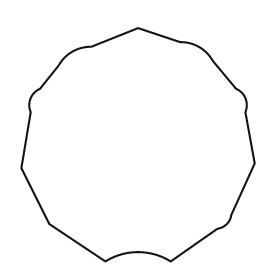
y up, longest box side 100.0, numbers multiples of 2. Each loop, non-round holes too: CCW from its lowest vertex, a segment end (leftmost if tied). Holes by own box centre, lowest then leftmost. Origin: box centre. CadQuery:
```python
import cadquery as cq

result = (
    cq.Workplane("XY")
    .moveTo(-14.0, -50.0)
    .threePointArc((0.0, -46.0), (14.0, -50.0))
    .lineTo(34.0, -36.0)
    .threePointArc((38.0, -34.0), (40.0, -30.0))
    .lineTo(50.0, -8.0)
    .lineTo(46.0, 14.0)
    .threePointArc((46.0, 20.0), (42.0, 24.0))
    .lineTo(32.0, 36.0)
    .threePointArc((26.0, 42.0), (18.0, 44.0))
    .lineTo(0.0, 50.0)
    .lineTo(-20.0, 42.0)
    .threePointArc((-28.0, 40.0), (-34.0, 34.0))
    .lineTo(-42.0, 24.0)
    .threePointArc((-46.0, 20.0), (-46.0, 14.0))
    .lineTo(-50.0, -10.0)
    .lineTo(-38.0, -34.0)
    .close()
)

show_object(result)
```